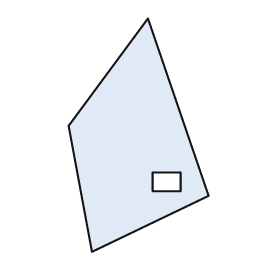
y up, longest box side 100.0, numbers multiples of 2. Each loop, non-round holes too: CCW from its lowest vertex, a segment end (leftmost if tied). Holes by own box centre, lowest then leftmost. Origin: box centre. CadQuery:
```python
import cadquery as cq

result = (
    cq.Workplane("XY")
    .moveTo(-20.0, -50.0)
    .lineTo(30.0, -26.0)
    .lineTo(4.0, 50.0)
    .lineTo(-30.0, 4.0)
    .close()
    .moveTo(6.0, -24.0)
    .lineTo(18.0, -24.0)
    .lineTo(18.0, -16.0)
    .lineTo(6.0, -16.0)
    .close()
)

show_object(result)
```